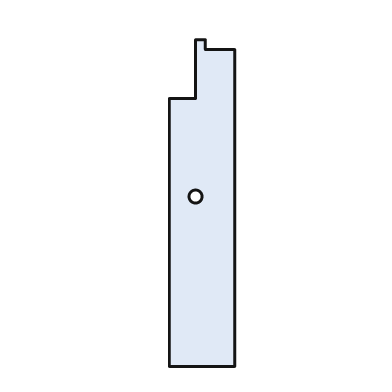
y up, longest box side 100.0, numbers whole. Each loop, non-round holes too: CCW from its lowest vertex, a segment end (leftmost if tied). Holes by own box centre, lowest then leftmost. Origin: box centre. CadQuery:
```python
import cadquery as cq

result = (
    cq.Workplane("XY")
    .moveTo(-10.0, -50.0)
    .lineTo(10.0, -50.0)
    .lineTo(10.0, 47.0)
    .lineTo(1.0, 47.0)
    .lineTo(1.0, 50.0)
    .lineTo(-2.0, 50.0)
    .lineTo(-2.0, 32.0)
    .lineTo(-10.0, 32.0)
    .close()
    .moveTo(-2.0, 2.0)
    .circle(2.0)
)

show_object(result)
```